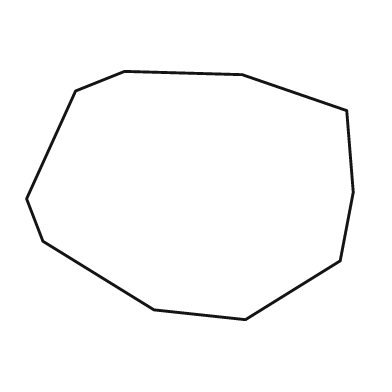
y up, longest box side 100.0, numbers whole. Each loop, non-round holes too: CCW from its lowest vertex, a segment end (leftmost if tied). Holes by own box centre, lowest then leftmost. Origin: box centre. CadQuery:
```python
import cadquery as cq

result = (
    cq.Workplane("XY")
    .moveTo(17.0, -38.0)
    .lineTo(46.0, -20.0)
    .lineTo(50.0, 1.0)
    .lineTo(48.0, 26.0)
    .lineTo(16.0, 37.0)
    .lineTo(-20.0, 38.0)
    .lineTo(-35.0, 32.0)
    .lineTo(-50.0, -1.0)
    .lineTo(-45.0, -14.0)
    .lineTo(-11.0, -35.0)
    .close()
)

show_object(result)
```